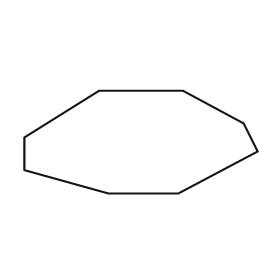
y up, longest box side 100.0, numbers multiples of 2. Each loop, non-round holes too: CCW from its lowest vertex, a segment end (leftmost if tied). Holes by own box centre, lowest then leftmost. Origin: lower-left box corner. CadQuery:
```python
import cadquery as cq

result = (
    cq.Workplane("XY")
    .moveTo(36.0, 0.0)
    .lineTo(66.0, 0.0)
    .lineTo(100.0, 18.0)
    .lineTo(94.0, 30.0)
    .lineTo(68.0, 44.0)
    .lineTo(32.0, 44.0)
    .lineTo(0.0, 24.0)
    .lineTo(0.0, 10.0)
    .close()
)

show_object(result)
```